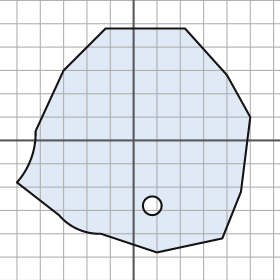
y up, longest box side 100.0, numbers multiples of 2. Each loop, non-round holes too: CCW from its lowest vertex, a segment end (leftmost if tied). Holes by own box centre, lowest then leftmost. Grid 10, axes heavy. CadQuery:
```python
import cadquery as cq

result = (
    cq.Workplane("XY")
    .moveTo(10.0, -48.0)
    .lineTo(38.0, -42.0)
    .lineTo(46.0, -22.0)
    .lineTo(50.0, 10.0)
    .lineTo(40.0, 28.0)
    .lineTo(22.0, 48.0)
    .lineTo(-12.0, 48.0)
    .lineTo(-30.0, 30.0)
    .lineTo(-42.0, 4.0)
    .threePointArc((-44.0, -8.0), (-50.0, -18.0))
    .lineTo(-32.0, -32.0)
    .threePointArc((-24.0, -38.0), (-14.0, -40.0))
    .close()
    .moveTo(8.0, -28.0)
    .circle(4.0)
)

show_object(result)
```